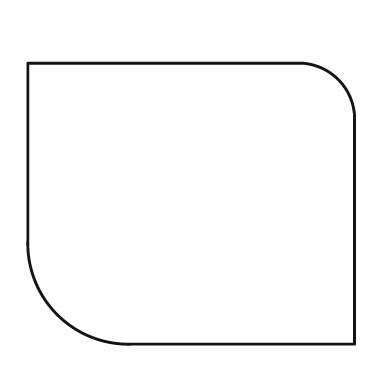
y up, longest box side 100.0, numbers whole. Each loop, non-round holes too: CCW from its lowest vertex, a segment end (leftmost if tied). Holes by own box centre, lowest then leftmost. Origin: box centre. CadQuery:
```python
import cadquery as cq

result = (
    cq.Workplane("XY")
    .moveTo(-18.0, -43.0)
    .lineTo(50.0, -43.0)
    .lineTo(50.0, 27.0)
    .threePointArc((45.0, 38.0), (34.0, 43.0))
    .lineTo(-50.0, 43.0)
    .lineTo(-50.0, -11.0)
    .threePointArc((-41.0, -34.0), (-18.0, -43.0))
    .close()
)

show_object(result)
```